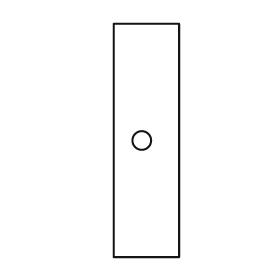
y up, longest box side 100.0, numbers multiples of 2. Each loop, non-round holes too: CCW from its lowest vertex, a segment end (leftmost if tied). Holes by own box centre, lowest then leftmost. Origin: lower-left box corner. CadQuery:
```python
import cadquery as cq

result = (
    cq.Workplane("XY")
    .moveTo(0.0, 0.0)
    .lineTo(28.0, 0.0)
    .lineTo(28.0, 100.0)
    .lineTo(0.0, 100.0)
    .close()
    .moveTo(12.0, 50.0)
    .circle(4.0)
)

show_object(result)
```